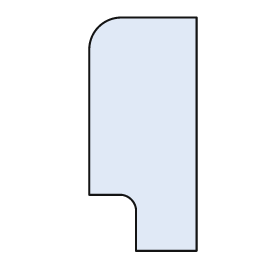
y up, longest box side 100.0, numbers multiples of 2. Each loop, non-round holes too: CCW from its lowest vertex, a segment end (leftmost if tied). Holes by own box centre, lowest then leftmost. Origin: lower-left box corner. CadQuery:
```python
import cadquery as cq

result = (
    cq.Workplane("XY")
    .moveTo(20.0, 0.0)
    .lineTo(46.0, 0.0)
    .lineTo(46.0, 100.0)
    .lineTo(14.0, 100.0)
    .threePointArc((4.0, 96.0), (0.0, 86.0))
    .lineTo(0.0, 24.0)
    .lineTo(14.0, 24.0)
    .threePointArc((18.0, 22.0), (20.0, 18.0))
    .close()
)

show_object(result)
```